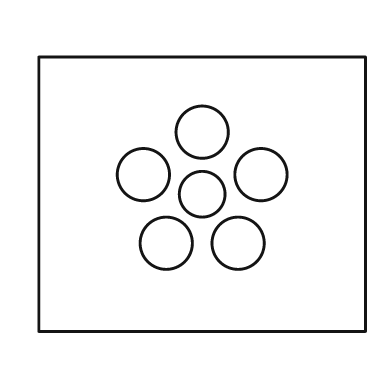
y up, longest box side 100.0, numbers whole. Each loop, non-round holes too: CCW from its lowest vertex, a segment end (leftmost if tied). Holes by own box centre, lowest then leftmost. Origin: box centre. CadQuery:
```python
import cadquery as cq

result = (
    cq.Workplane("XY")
    .moveTo(-50.0, -42.0)
    .lineTo(50.0, -42.0)
    .lineTo(50.0, 42.0)
    .lineTo(-50.0, 42.0)
    .close()
    .moveTo(-11.0, -15.0)
    .circle(8.0)
    .moveTo(11.0, -15.0)
    .circle(8.0)
    .moveTo(0.0, 0.0)
    .circle(7.0)
    .moveTo(-18.0, 6.0)
    .circle(8.0)
    .moveTo(18.0, 6.0)
    .circle(8.0)
    .moveTo(0.0, 19.0)
    .circle(8.0)
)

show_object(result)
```